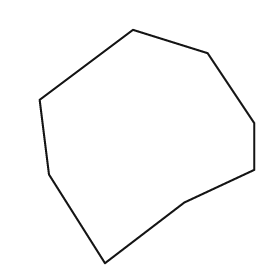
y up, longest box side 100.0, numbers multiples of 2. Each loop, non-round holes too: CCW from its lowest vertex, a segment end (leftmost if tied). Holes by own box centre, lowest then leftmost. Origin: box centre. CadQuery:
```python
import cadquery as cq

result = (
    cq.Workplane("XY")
    .moveTo(-18.0, -50.0)
    .lineTo(16.0, -24.0)
    .lineTo(46.0, -10.0)
    .lineTo(46.0, 10.0)
    .lineTo(26.0, 40.0)
    .lineTo(-6.0, 50.0)
    .lineTo(-46.0, 20.0)
    .lineTo(-42.0, -12.0)
    .close()
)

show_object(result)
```